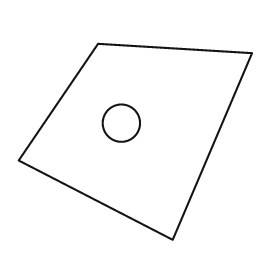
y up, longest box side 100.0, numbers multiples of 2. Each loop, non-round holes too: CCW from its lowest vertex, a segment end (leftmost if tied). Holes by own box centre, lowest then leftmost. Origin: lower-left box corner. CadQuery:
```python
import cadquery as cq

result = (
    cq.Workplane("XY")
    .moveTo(66.0, 0.0)
    .lineTo(100.0, 80.0)
    .lineTo(34.0, 84.0)
    .lineTo(0.0, 34.0)
    .close()
    .moveTo(44.0, 50.0)
    .circle(8.0)
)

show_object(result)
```